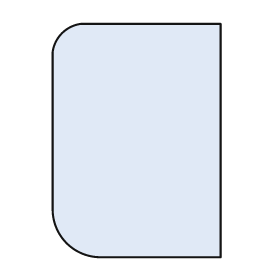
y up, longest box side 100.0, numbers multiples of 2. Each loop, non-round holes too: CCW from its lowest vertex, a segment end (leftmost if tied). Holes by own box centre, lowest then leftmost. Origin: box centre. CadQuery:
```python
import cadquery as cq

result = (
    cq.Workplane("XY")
    .moveTo(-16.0, -50.0)
    .lineTo(36.0, -50.0)
    .lineTo(36.0, 50.0)
    .lineTo(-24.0, 50.0)
    .threePointArc((-32.0, 46.0), (-36.0, 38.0))
    .lineTo(-36.0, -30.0)
    .threePointArc((-30.0, -44.0), (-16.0, -50.0))
    .close()
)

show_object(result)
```